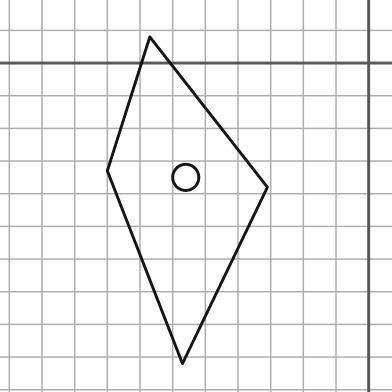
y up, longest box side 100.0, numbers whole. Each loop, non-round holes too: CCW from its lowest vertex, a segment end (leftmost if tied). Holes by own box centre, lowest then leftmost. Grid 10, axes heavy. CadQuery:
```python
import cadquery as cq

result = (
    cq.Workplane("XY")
    .moveTo(-57.0, -92.0)
    .lineTo(-31.0, -38.0)
    .lineTo(-67.0, 8.0)
    .lineTo(-80.0, -33.0)
    .close()
    .moveTo(-56.0, -35.0)
    .circle(4.0)
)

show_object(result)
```